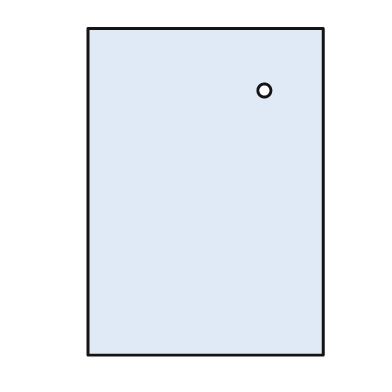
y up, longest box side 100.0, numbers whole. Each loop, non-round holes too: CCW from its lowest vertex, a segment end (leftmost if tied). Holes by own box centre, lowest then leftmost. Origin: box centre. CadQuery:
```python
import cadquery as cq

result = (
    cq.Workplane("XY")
    .moveTo(-36.0, -50.0)
    .lineTo(36.0, -50.0)
    .lineTo(36.0, 50.0)
    .lineTo(-36.0, 50.0)
    .close()
    .moveTo(18.0, 31.0)
    .circle(2.0)
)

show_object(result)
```